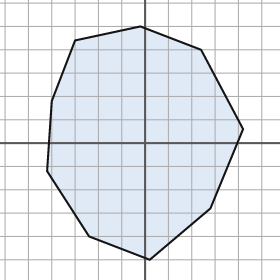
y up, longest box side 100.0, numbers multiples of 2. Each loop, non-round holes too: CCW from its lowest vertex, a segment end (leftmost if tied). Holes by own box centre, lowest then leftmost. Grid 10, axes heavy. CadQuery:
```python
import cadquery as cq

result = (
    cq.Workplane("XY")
    .moveTo(2.0, -50.0)
    .lineTo(28.0, -28.0)
    .lineTo(42.0, 6.0)
    .lineTo(24.0, 40.0)
    .lineTo(-2.0, 50.0)
    .lineTo(-30.0, 44.0)
    .lineTo(-40.0, 18.0)
    .lineTo(-42.0, -12.0)
    .lineTo(-24.0, -40.0)
    .close()
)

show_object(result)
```